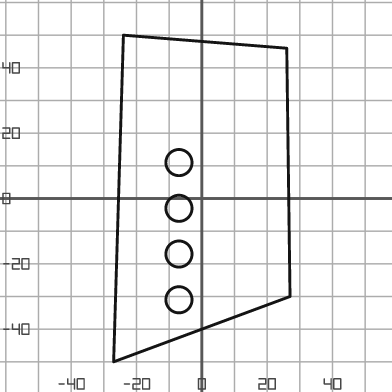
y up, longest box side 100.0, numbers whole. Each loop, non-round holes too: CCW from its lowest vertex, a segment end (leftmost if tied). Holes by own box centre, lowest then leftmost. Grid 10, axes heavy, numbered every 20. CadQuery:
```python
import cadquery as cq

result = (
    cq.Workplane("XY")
    .moveTo(-27.0, -50.0)
    .lineTo(27.0, -30.0)
    .lineTo(26.0, 46.0)
    .lineTo(-24.0, 50.0)
    .close()
    .moveTo(-7.0, -31.0)
    .circle(4.0)
    .moveTo(-7.0, -17.0)
    .circle(4.0)
    .moveTo(-7.0, -3.0)
    .circle(4.0)
    .moveTo(-7.0, 11.0)
    .circle(4.0)
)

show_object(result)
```